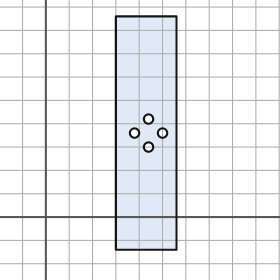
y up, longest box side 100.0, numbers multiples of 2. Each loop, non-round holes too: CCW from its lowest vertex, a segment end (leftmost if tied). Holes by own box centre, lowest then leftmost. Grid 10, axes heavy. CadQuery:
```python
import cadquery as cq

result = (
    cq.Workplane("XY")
    .moveTo(30.0, -14.0)
    .lineTo(56.0, -14.0)
    .lineTo(56.0, 86.0)
    .lineTo(30.0, 86.0)
    .close()
    .moveTo(44.0, 30.0)
    .circle(2.0)
    .moveTo(38.0, 36.0)
    .circle(2.0)
    .moveTo(50.0, 36.0)
    .circle(2.0)
    .moveTo(44.0, 42.0)
    .circle(2.0)
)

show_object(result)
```